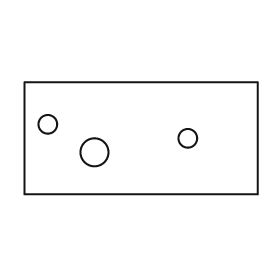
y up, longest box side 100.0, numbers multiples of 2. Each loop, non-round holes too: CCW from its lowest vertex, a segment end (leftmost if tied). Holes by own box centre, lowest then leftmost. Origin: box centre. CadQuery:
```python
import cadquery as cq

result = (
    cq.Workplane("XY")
    .moveTo(-50.0, -24.0)
    .lineTo(50.0, -24.0)
    .lineTo(50.0, 24.0)
    .lineTo(-50.0, 24.0)
    .close()
    .moveTo(-20.0, -6.0)
    .circle(6.0)
    .moveTo(20.0, 0.0)
    .circle(4.0)
    .moveTo(-40.0, 6.0)
    .circle(4.0)
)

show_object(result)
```